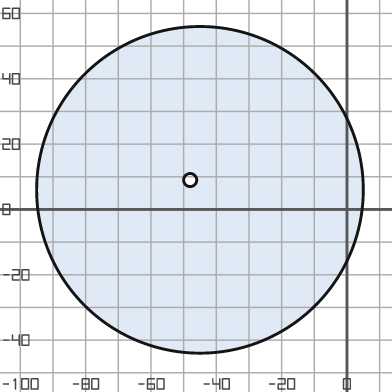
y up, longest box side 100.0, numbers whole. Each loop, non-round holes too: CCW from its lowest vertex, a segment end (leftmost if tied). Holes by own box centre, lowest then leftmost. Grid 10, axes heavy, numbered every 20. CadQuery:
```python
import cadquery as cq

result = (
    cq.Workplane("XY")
    .moveTo(-45.0, 6.0)
    .circle(50.0)
    .moveTo(-48.0, 9.0)
    .circle(2.0)
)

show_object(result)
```